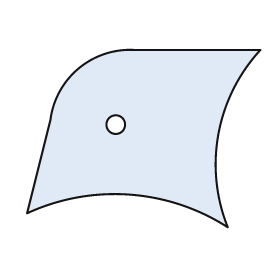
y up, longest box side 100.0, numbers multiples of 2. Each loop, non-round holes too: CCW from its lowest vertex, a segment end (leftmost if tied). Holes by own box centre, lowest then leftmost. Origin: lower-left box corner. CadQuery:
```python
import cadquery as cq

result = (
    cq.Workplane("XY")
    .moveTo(86.0, 0.0)
    .threePointArc((82.0, 40.0), (100.0, 76.0))
    .lineTo(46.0, 76.0)
    .threePointArc((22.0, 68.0), (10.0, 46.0))
    .lineTo(0.0, 6.0)
    .threePointArc((44.0, 14.0), (86.0, 0.0))
    .close()
    .moveTo(38.0, 44.0)
    .circle(4.0)
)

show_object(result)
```